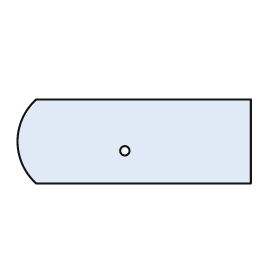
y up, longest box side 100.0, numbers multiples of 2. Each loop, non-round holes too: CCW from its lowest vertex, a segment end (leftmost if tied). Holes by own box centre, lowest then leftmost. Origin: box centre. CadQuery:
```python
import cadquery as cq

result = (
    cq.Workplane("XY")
    .moveTo(-42.0, -18.0)
    .lineTo(50.0, -18.0)
    .lineTo(50.0, 18.0)
    .lineTo(-42.0, 18.0)
    .threePointArc((-50.0, 0.0), (-42.0, -18.0))
    .close()
    .moveTo(-4.0, -4.0)
    .circle(2.0)
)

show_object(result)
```